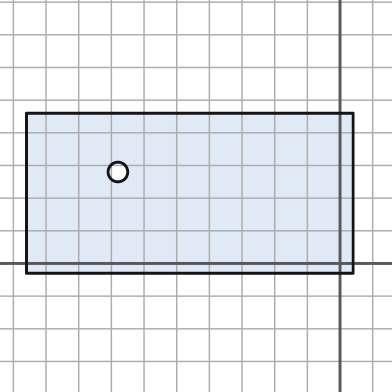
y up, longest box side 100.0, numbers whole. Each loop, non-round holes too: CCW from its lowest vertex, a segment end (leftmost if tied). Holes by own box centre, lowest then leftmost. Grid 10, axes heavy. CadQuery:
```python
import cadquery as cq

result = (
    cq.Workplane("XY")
    .moveTo(-96.0, -3.0)
    .lineTo(4.0, -3.0)
    .lineTo(4.0, 46.0)
    .lineTo(-96.0, 46.0)
    .close()
    .moveTo(-68.0, 28.0)
    .circle(3.0)
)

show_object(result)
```